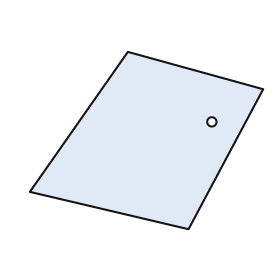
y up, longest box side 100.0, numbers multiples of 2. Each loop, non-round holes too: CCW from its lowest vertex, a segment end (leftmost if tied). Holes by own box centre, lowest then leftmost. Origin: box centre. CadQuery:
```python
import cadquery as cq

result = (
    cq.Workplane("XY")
    .moveTo(18.0, -38.0)
    .lineTo(50.0, 22.0)
    .lineTo(-8.0, 38.0)
    .lineTo(-50.0, -22.0)
    .close()
    .moveTo(28.0, 8.0)
    .circle(2.0)
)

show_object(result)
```